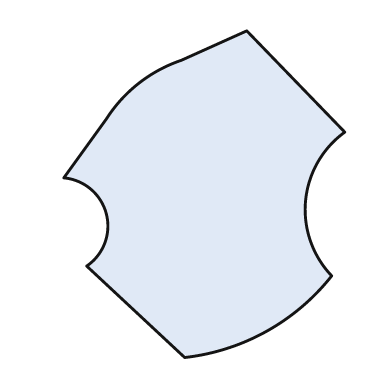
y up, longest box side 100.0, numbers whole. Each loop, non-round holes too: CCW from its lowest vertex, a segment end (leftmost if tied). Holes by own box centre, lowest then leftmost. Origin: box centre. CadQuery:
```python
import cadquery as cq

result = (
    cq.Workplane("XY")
    .moveTo(-6.0, -50.0)
    .threePointArc((19.0, -42.0), (39.0, -25.0))
    .threePointArc((31.0, -2.0), (43.0, 19.0))
    .lineTo(13.0, 50.0)
    .lineTo(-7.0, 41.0)
    .threePointArc((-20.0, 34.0), (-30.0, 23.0))
    .lineTo(-43.0, 5.0)
    .threePointArc((-30.0, -6.0), (-36.0, -22.0))
    .close()
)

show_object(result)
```